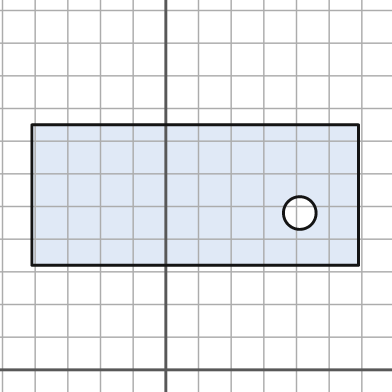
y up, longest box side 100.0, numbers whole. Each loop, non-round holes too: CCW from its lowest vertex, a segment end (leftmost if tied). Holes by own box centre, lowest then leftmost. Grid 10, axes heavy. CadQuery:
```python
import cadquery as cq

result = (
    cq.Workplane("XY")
    .moveTo(-41.0, 32.0)
    .lineTo(59.0, 32.0)
    .lineTo(59.0, 75.0)
    .lineTo(-41.0, 75.0)
    .close()
    .moveTo(41.0, 48.0)
    .circle(5.0)
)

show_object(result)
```